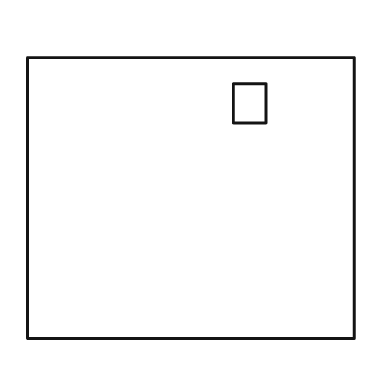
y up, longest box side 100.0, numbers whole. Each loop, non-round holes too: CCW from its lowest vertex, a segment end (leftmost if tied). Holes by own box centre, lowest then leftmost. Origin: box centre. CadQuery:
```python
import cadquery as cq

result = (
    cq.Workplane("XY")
    .moveTo(-50.0, -43.0)
    .lineTo(50.0, -43.0)
    .lineTo(50.0, 43.0)
    .lineTo(-50.0, 43.0)
    .close()
    .moveTo(13.0, 23.0)
    .lineTo(23.0, 23.0)
    .lineTo(23.0, 35.0)
    .lineTo(13.0, 35.0)
    .close()
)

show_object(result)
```